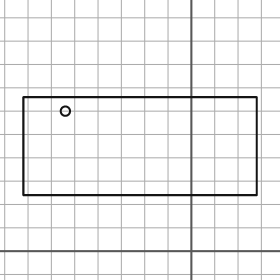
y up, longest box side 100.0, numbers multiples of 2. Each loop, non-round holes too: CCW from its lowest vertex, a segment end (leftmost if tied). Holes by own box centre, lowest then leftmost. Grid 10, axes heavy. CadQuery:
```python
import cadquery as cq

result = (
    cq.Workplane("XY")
    .moveTo(-72.0, 24.0)
    .lineTo(28.0, 24.0)
    .lineTo(28.0, 66.0)
    .lineTo(-72.0, 66.0)
    .close()
    .moveTo(-54.0, 60.0)
    .circle(2.0)
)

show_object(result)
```